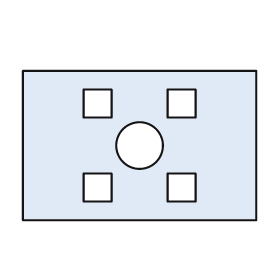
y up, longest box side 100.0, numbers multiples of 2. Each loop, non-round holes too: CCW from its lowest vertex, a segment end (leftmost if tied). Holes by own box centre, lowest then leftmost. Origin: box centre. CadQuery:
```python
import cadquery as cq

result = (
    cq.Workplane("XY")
    .moveTo(-50.0, -32.0)
    .lineTo(50.0, -32.0)
    .lineTo(50.0, 32.0)
    .lineTo(-50.0, 32.0)
    .close()
    .moveTo(-24.0, -24.0)
    .lineTo(-12.0, -24.0)
    .lineTo(-12.0, -12.0)
    .lineTo(-24.0, -12.0)
    .close()
    .moveTo(12.0, -24.0)
    .lineTo(24.0, -24.0)
    .lineTo(24.0, -12.0)
    .lineTo(12.0, -12.0)
    .close()
    .moveTo(0.0, 0.0)
    .circle(10.0)
    .moveTo(-24.0, 12.0)
    .lineTo(-12.0, 12.0)
    .lineTo(-12.0, 24.0)
    .lineTo(-24.0, 24.0)
    .close()
    .moveTo(12.0, 12.0)
    .lineTo(24.0, 12.0)
    .lineTo(24.0, 24.0)
    .lineTo(12.0, 24.0)
    .close()
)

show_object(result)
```